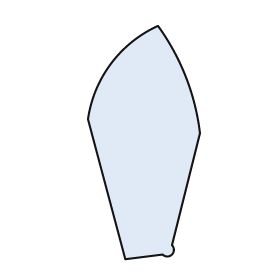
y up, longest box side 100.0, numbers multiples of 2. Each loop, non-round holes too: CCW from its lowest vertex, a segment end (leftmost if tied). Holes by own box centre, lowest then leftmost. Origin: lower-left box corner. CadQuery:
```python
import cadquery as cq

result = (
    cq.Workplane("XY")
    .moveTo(16.0, 0.0)
    .lineTo(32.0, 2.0)
    .threePointArc((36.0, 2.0), (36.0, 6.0))
    .lineTo(48.0, 54.0)
    .threePointArc((42.0, 78.0), (30.0, 100.0))
    .threePointArc((10.0, 84.0), (0.0, 60.0))
    .close()
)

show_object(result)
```